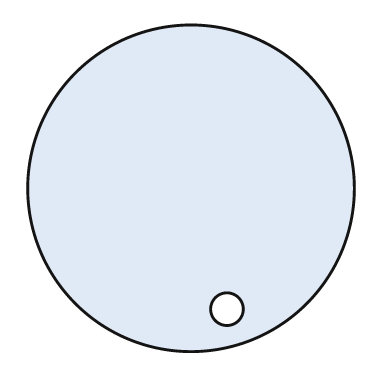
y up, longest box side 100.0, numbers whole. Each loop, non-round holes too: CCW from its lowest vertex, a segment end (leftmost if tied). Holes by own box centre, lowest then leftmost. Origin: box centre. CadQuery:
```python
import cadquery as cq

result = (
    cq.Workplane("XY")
    .moveTo(0.0, 0.0)
    .circle(50.0)
    .moveTo(11.0, -37.0)
    .circle(5.0)
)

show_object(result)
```